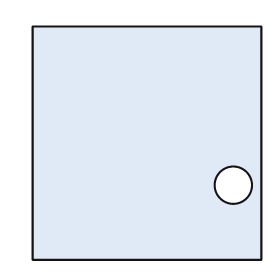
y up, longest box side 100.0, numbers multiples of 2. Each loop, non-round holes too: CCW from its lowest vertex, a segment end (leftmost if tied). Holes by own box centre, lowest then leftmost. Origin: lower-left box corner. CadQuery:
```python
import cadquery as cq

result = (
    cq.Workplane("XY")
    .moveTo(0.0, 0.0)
    .lineTo(98.0, 0.0)
    .lineTo(98.0, 100.0)
    .lineTo(0.0, 100.0)
    .close()
    .moveTo(86.0, 32.0)
    .circle(8.0)
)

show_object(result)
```